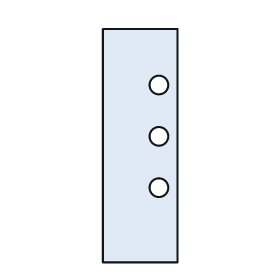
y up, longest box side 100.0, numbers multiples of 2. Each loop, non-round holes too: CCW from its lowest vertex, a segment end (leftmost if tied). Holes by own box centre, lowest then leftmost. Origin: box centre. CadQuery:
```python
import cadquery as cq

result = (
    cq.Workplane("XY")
    .moveTo(-16.0, -50.0)
    .lineTo(16.0, -50.0)
    .lineTo(16.0, 50.0)
    .lineTo(-16.0, 50.0)
    .close()
    .moveTo(8.0, -18.0)
    .circle(4.0)
    .moveTo(8.0, 4.0)
    .circle(4.0)
    .moveTo(8.0, 26.0)
    .circle(4.0)
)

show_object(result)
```